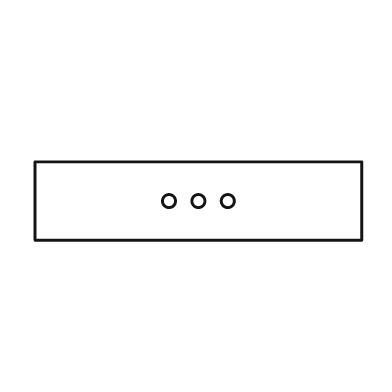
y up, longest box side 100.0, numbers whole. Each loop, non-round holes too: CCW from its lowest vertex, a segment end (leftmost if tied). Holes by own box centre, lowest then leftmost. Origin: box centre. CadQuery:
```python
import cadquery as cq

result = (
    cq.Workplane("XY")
    .moveTo(-50.0, -12.0)
    .lineTo(50.0, -12.0)
    .lineTo(50.0, 12.0)
    .lineTo(-50.0, 12.0)
    .close()
    .moveTo(-9.0, 0.0)
    .circle(2.0)
    .moveTo(0.0, 0.0)
    .circle(2.0)
    .moveTo(9.0, 0.0)
    .circle(2.0)
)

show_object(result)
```